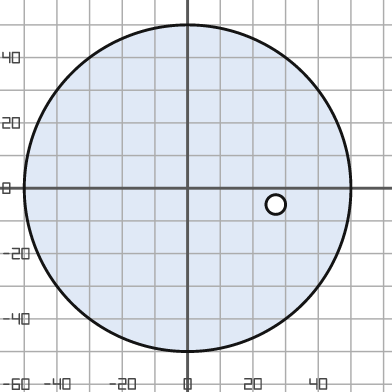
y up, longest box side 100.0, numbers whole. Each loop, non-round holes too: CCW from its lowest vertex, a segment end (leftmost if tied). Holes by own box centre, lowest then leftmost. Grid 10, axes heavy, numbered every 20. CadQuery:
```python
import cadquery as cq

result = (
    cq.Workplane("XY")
    .moveTo(0.0, 0.0)
    .circle(50.0)
    .moveTo(27.0, -5.0)
    .circle(3.0)
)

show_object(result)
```